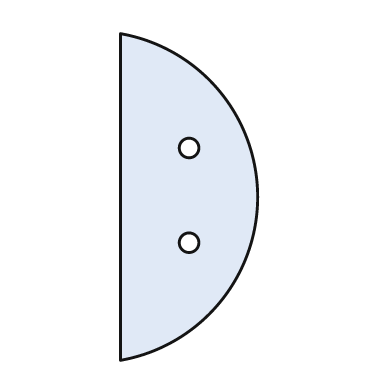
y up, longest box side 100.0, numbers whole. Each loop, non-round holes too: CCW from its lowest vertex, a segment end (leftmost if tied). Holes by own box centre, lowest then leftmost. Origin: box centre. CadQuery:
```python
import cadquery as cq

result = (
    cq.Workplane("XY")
    .moveTo(-21.0, -50.0)
    .threePointArc((21.0, 0.0), (-21.0, 50.0))
    .close()
    .moveTo(0.0, -14.0)
    .circle(3.0)
    .moveTo(0.0, 15.0)
    .circle(3.0)
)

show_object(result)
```